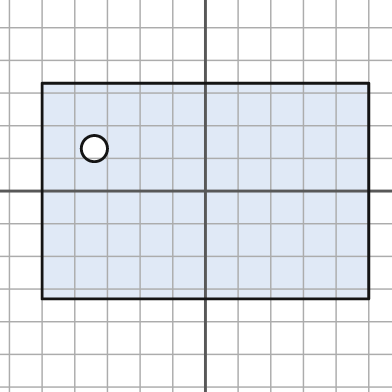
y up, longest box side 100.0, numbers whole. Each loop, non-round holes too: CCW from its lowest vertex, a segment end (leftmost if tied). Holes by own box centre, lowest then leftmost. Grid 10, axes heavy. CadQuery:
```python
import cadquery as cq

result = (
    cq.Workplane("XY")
    .moveTo(-50.0, -33.0)
    .lineTo(50.0, -33.0)
    .lineTo(50.0, 33.0)
    .lineTo(-50.0, 33.0)
    .close()
    .moveTo(-34.0, 13.0)
    .circle(4.0)
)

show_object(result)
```